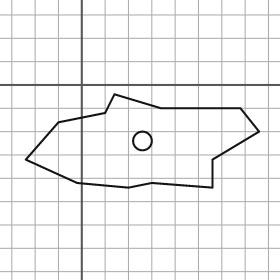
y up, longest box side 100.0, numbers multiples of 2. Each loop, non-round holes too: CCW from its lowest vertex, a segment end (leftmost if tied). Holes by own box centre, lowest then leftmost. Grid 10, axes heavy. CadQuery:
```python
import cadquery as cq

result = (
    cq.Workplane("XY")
    .moveTo(20.0, -44.0)
    .lineTo(30.0, -42.0)
    .lineTo(56.0, -44.0)
    .lineTo(56.0, -32.0)
    .lineTo(76.0, -20.0)
    .lineTo(68.0, -10.0)
    .lineTo(34.0, -10.0)
    .lineTo(14.0, -4.0)
    .lineTo(10.0, -12.0)
    .lineTo(-10.0, -16.0)
    .lineTo(-24.0, -32.0)
    .lineTo(-2.0, -42.0)
    .close()
    .moveTo(26.0, -24.0)
    .circle(4.0)
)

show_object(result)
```